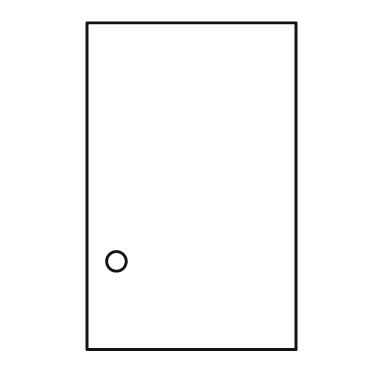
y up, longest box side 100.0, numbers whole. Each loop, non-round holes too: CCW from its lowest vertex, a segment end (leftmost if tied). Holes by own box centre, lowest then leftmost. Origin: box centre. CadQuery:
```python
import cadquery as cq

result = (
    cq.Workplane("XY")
    .moveTo(-32.0, -50.0)
    .lineTo(32.0, -50.0)
    .lineTo(32.0, 50.0)
    .lineTo(-32.0, 50.0)
    .close()
    .moveTo(-23.0, -23.0)
    .circle(3.0)
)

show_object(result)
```